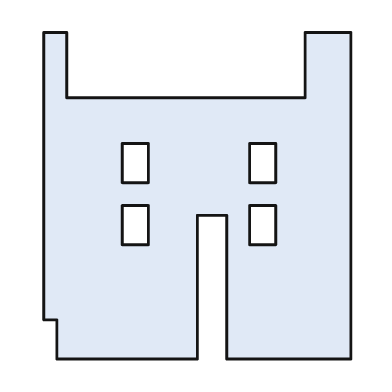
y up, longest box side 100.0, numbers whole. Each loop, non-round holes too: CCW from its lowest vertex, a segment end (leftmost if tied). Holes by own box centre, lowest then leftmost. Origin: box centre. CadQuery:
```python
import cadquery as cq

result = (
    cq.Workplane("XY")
    .moveTo(-43.0, -50.0)
    .lineTo(0.0, -50.0)
    .lineTo(0.0, -6.0)
    .lineTo(9.0, -6.0)
    .lineTo(9.0, -50.0)
    .lineTo(47.0, -50.0)
    .lineTo(47.0, 50.0)
    .lineTo(33.0, 50.0)
    .lineTo(33.0, 30.0)
    .lineTo(-40.0, 30.0)
    .lineTo(-40.0, 50.0)
    .lineTo(-47.0, 50.0)
    .lineTo(-47.0, -38.0)
    .lineTo(-43.0, -38.0)
    .close()
    .moveTo(-23.0, -15.0)
    .lineTo(-15.0, -15.0)
    .lineTo(-15.0, -3.0)
    .lineTo(-23.0, -3.0)
    .close()
    .moveTo(16.0, -15.0)
    .lineTo(24.0, -15.0)
    .lineTo(24.0, -3.0)
    .lineTo(16.0, -3.0)
    .close()
    .moveTo(-23.0, 4.0)
    .lineTo(-15.0, 4.0)
    .lineTo(-15.0, 16.0)
    .lineTo(-23.0, 16.0)
    .close()
    .moveTo(16.0, 4.0)
    .lineTo(24.0, 4.0)
    .lineTo(24.0, 16.0)
    .lineTo(16.0, 16.0)
    .close()
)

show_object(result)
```